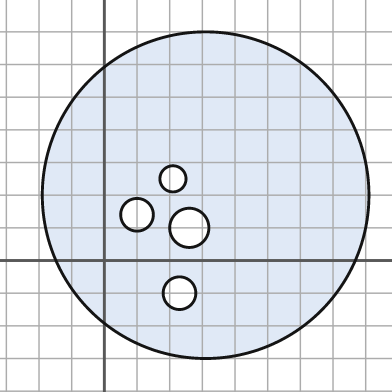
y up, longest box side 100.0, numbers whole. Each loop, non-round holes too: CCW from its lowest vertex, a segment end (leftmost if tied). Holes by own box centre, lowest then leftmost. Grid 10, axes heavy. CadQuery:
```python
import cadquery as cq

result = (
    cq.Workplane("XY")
    .moveTo(31.0, 20.0)
    .circle(50.0)
    .moveTo(23.0, -10.0)
    .circle(5.0)
    .moveTo(26.0, 10.0)
    .circle(6.0)
    .moveTo(10.0, 14.0)
    .circle(5.0)
    .moveTo(21.0, 25.0)
    .circle(4.0)
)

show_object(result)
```